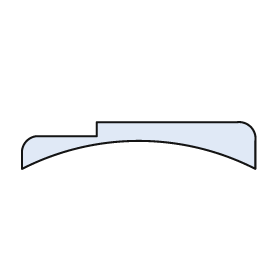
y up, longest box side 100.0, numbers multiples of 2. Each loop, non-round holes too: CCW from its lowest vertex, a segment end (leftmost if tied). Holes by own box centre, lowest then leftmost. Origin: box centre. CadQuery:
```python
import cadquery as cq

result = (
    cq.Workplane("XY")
    .moveTo(-50.0, -10.0)
    .threePointArc((0.0, 2.0), (50.0, -10.0))
    .lineTo(50.0, 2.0)
    .threePointArc((48.0, 8.0), (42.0, 10.0))
    .lineTo(-18.0, 10.0)
    .lineTo(-18.0, 4.0)
    .lineTo(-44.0, 4.0)
    .threePointArc((-48.0, 2.0), (-50.0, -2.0))
    .close()
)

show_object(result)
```